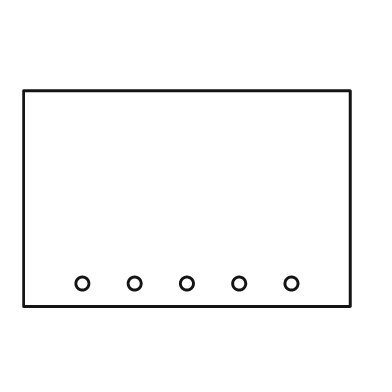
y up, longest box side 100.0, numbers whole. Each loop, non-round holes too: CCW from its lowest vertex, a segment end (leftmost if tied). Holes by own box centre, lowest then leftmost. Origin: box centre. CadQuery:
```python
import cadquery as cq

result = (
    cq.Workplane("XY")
    .moveTo(-50.0, -33.0)
    .lineTo(50.0, -33.0)
    .lineTo(50.0, 33.0)
    .lineTo(-50.0, 33.0)
    .close()
    .moveTo(-32.0, -26.0)
    .circle(2.0)
    .moveTo(-16.0, -26.0)
    .circle(2.0)
    .moveTo(0.0, -26.0)
    .circle(2.0)
    .moveTo(16.0, -26.0)
    .circle(2.0)
    .moveTo(32.0, -26.0)
    .circle(2.0)
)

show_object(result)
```